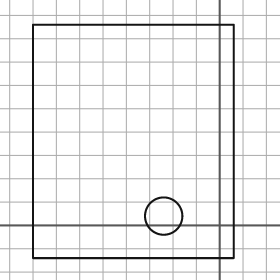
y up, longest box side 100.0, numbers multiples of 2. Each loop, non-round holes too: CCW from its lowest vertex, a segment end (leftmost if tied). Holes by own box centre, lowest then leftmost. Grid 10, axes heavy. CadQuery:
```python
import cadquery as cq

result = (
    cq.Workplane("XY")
    .moveTo(-80.0, -14.0)
    .lineTo(6.0, -14.0)
    .lineTo(6.0, 86.0)
    .lineTo(-80.0, 86.0)
    .close()
    .moveTo(-24.0, 4.0)
    .circle(8.0)
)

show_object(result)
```